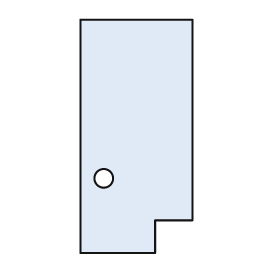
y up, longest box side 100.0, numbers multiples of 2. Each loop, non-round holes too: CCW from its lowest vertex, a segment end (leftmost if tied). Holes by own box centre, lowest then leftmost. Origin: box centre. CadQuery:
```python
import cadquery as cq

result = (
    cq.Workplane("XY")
    .moveTo(-24.0, -50.0)
    .lineTo(8.0, -50.0)
    .lineTo(8.0, -36.0)
    .lineTo(24.0, -36.0)
    .lineTo(24.0, 50.0)
    .lineTo(-24.0, 50.0)
    .close()
    .moveTo(-14.0, -18.0)
    .circle(4.0)
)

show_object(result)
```